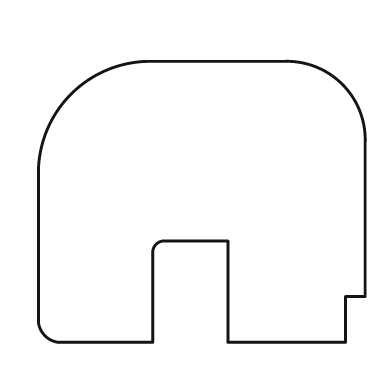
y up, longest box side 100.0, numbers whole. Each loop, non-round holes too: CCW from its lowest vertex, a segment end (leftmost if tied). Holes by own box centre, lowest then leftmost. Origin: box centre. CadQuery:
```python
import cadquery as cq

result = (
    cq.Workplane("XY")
    .moveTo(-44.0, -43.0)
    .lineTo(-15.0, -43.0)
    .lineTo(-15.0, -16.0)
    .threePointArc((-14.0, -13.0), (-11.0, -12.0))
    .lineTo(8.0, -12.0)
    .lineTo(8.0, -43.0)
    .lineTo(44.0, -43.0)
    .lineTo(44.0, -29.0)
    .lineTo(50.0, -29.0)
    .lineTo(50.0, 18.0)
    .threePointArc((43.0, 36.0), (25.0, 43.0))
    .lineTo(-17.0, 43.0)
    .threePointArc((-40.0, 33.0), (-50.0, 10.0))
    .lineTo(-50.0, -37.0)
    .threePointArc((-48.0, -41.0), (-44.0, -43.0))
    .close()
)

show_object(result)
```